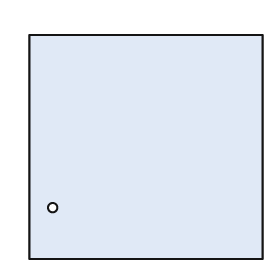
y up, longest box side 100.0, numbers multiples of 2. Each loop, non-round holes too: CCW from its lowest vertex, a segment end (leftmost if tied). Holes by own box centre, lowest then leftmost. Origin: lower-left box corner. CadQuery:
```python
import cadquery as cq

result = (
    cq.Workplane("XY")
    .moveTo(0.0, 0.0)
    .lineTo(100.0, 0.0)
    .lineTo(100.0, 96.0)
    .lineTo(0.0, 96.0)
    .close()
    .moveTo(10.0, 22.0)
    .circle(2.0)
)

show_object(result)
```